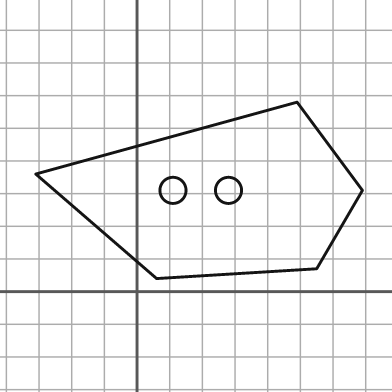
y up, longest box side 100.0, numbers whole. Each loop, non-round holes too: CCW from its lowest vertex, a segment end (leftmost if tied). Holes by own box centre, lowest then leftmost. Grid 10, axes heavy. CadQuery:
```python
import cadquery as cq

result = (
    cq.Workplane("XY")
    .moveTo(6.0, 4.0)
    .lineTo(55.0, 7.0)
    .lineTo(69.0, 31.0)
    .lineTo(49.0, 58.0)
    .lineTo(-31.0, 36.0)
    .close()
    .moveTo(11.0, 31.0)
    .circle(4.0)
    .moveTo(28.0, 31.0)
    .circle(4.0)
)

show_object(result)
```